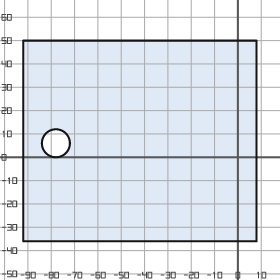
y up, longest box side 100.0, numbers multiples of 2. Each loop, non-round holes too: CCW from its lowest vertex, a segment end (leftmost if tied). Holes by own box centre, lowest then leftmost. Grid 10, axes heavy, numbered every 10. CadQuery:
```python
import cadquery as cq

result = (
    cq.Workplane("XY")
    .moveTo(-92.0, -36.0)
    .lineTo(8.0, -36.0)
    .lineTo(8.0, 50.0)
    .lineTo(-92.0, 50.0)
    .close()
    .moveTo(-78.0, 6.0)
    .circle(6.0)
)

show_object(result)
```